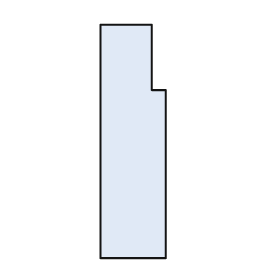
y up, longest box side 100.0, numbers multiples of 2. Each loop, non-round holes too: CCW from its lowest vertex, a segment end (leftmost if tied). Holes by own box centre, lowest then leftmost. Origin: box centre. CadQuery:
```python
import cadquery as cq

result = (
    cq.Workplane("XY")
    .moveTo(-14.0, -50.0)
    .lineTo(14.0, -50.0)
    .lineTo(14.0, 22.0)
    .lineTo(8.0, 22.0)
    .lineTo(8.0, 50.0)
    .lineTo(-14.0, 50.0)
    .close()
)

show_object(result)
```